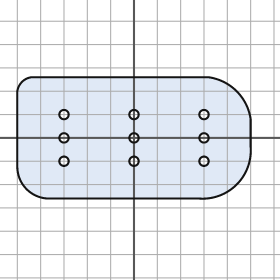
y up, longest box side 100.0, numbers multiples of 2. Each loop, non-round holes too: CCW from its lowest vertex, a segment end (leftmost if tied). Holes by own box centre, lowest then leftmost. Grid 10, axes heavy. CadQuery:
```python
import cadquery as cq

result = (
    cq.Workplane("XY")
    .moveTo(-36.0, -26.0)
    .lineTo(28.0, -26.0)
    .threePointArc((44.0, -20.0), (50.0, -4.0))
    .lineTo(50.0, 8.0)
    .threePointArc((44.0, 20.0), (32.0, 26.0))
    .lineTo(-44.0, 26.0)
    .threePointArc((-48.0, 24.0), (-50.0, 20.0))
    .lineTo(-50.0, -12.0)
    .threePointArc((-46.0, -22.0), (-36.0, -26.0))
    .close()
    .moveTo(-30.0, -10.0)
    .circle(2.0)
    .moveTo(0.0, -10.0)
    .circle(2.0)
    .moveTo(30.0, -10.0)
    .circle(2.0)
    .moveTo(-30.0, 0.0)
    .circle(2.0)
    .moveTo(0.0, 0.0)
    .circle(2.0)
    .moveTo(30.0, 0.0)
    .circle(2.0)
    .moveTo(-30.0, 10.0)
    .circle(2.0)
    .moveTo(0.0, 10.0)
    .circle(2.0)
    .moveTo(30.0, 10.0)
    .circle(2.0)
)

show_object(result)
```